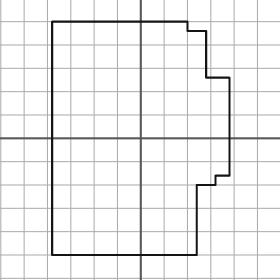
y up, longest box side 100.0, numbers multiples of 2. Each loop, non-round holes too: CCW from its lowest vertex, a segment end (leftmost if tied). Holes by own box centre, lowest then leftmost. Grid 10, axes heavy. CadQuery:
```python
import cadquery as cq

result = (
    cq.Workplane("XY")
    .moveTo(-38.0, -50.0)
    .lineTo(24.0, -50.0)
    .lineTo(24.0, -20.0)
    .lineTo(32.0, -20.0)
    .lineTo(32.0, -16.0)
    .lineTo(38.0, -16.0)
    .lineTo(38.0, 26.0)
    .lineTo(28.0, 26.0)
    .lineTo(28.0, 46.0)
    .lineTo(20.0, 46.0)
    .lineTo(20.0, 50.0)
    .lineTo(-38.0, 50.0)
    .close()
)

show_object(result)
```